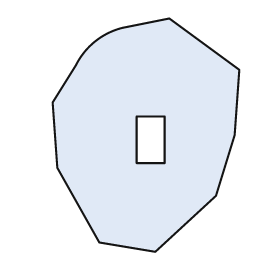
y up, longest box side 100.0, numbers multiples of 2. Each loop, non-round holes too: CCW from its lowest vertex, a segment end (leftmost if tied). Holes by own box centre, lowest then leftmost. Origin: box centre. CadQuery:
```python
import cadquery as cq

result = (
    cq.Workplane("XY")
    .moveTo(4.0, -50.0)
    .lineTo(30.0, -26.0)
    .lineTo(38.0, 0.0)
    .lineTo(40.0, 28.0)
    .lineTo(10.0, 50.0)
    .lineTo(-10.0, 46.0)
    .threePointArc((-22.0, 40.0), (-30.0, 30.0))
    .lineTo(-40.0, 14.0)
    .lineTo(-38.0, -14.0)
    .lineTo(-20.0, -46.0)
    .close()
    .moveTo(-4.0, -12.0)
    .lineTo(8.0, -12.0)
    .lineTo(8.0, 8.0)
    .lineTo(-4.0, 8.0)
    .close()
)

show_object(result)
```